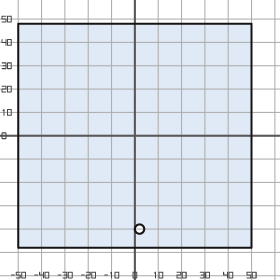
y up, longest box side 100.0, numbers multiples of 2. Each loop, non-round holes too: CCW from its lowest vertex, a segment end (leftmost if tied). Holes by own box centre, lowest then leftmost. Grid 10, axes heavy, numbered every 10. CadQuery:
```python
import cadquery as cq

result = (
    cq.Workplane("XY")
    .moveTo(-50.0, -48.0)
    .lineTo(50.0, -48.0)
    .lineTo(50.0, 48.0)
    .lineTo(-50.0, 48.0)
    .close()
    .moveTo(2.0, -40.0)
    .circle(2.0)
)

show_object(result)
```